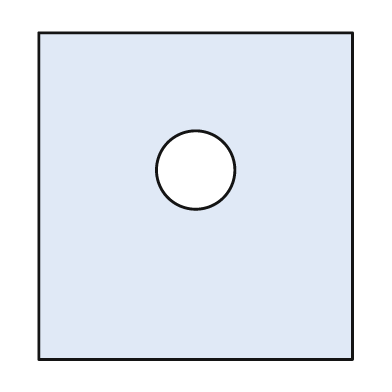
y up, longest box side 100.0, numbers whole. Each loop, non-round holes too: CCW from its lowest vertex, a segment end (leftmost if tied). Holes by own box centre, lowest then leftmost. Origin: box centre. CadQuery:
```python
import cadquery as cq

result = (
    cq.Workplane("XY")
    .moveTo(-48.0, -50.0)
    .lineTo(48.0, -50.0)
    .lineTo(48.0, 50.0)
    .lineTo(-48.0, 50.0)
    .close()
    .moveTo(0.0, 8.0)
    .circle(12.0)
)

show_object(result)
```